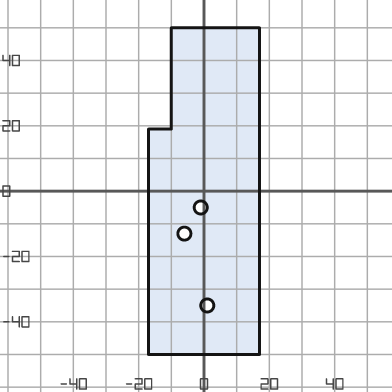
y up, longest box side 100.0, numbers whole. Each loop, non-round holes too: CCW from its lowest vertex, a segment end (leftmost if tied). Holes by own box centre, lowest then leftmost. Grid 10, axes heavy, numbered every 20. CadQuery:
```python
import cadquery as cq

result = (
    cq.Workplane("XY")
    .moveTo(-17.0, -50.0)
    .lineTo(17.0, -50.0)
    .lineTo(17.0, 50.0)
    .lineTo(-10.0, 50.0)
    .lineTo(-10.0, 19.0)
    .lineTo(-17.0, 19.0)
    .close()
    .moveTo(1.0, -35.0)
    .circle(2.0)
    .moveTo(-6.0, -13.0)
    .circle(2.0)
    .moveTo(-1.0, -5.0)
    .circle(2.0)
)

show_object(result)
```